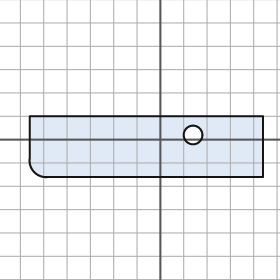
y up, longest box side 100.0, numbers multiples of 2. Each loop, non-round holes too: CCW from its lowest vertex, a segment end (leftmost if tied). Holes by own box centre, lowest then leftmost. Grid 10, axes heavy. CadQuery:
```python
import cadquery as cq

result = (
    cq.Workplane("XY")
    .moveTo(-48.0, -16.0)
    .lineTo(44.0, -16.0)
    .lineTo(44.0, 10.0)
    .lineTo(-56.0, 10.0)
    .lineTo(-56.0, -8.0)
    .threePointArc((-54.0, -14.0), (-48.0, -16.0))
    .close()
    .moveTo(14.0, 2.0)
    .circle(4.0)
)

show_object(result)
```